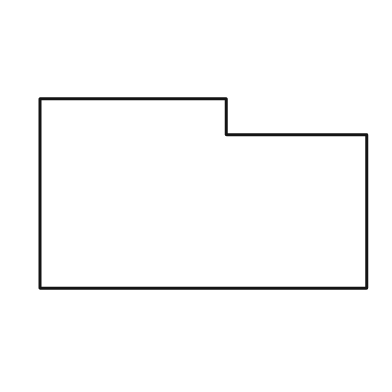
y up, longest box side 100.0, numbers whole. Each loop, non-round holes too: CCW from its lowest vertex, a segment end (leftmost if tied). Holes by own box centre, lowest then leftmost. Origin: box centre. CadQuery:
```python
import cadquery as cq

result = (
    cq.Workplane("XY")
    .moveTo(-50.0, -29.0)
    .lineTo(50.0, -29.0)
    .lineTo(50.0, 18.0)
    .lineTo(7.0, 18.0)
    .lineTo(7.0, 29.0)
    .lineTo(-50.0, 29.0)
    .close()
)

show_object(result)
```